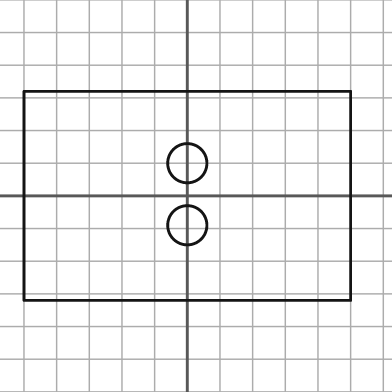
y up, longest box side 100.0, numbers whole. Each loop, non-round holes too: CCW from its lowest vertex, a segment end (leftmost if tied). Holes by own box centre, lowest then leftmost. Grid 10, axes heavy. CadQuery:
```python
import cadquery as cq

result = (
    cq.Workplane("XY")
    .moveTo(-50.0, -32.0)
    .lineTo(50.0, -32.0)
    .lineTo(50.0, 32.0)
    .lineTo(-50.0, 32.0)
    .close()
    .moveTo(0.0, -9.0)
    .circle(6.0)
    .moveTo(0.0, 10.0)
    .circle(6.0)
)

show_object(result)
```